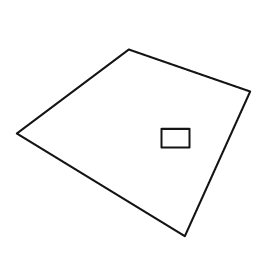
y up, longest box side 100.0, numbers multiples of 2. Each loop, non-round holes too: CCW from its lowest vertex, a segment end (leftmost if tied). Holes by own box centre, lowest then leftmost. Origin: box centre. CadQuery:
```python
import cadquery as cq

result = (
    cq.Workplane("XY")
    .moveTo(22.0, -40.0)
    .lineTo(50.0, 22.0)
    .lineTo(-2.0, 40.0)
    .lineTo(-50.0, 4.0)
    .close()
    .moveTo(12.0, -2.0)
    .lineTo(24.0, -2.0)
    .lineTo(24.0, 6.0)
    .lineTo(12.0, 6.0)
    .close()
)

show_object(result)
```